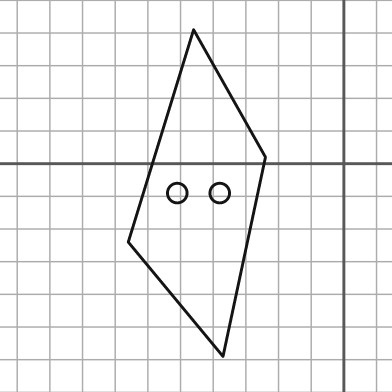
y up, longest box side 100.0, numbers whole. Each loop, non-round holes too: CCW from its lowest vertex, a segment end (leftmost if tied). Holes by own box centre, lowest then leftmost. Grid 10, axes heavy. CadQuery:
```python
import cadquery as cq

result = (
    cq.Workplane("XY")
    .moveTo(-37.0, -59.0)
    .lineTo(-24.0, 2.0)
    .lineTo(-46.0, 41.0)
    .lineTo(-66.0, -24.0)
    .close()
    .moveTo(-51.0, -9.0)
    .circle(3.0)
    .moveTo(-38.0, -9.0)
    .circle(3.0)
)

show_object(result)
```